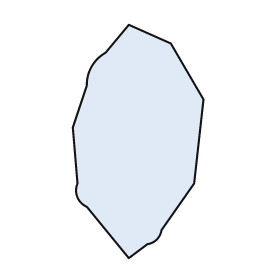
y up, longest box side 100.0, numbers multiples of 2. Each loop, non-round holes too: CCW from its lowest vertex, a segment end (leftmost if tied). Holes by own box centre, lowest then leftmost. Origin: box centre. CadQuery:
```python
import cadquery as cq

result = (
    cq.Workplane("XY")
    .moveTo(-4.0, -50.0)
    .lineTo(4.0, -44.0)
    .threePointArc((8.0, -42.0), (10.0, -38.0))
    .lineTo(24.0, -18.0)
    .lineTo(28.0, 18.0)
    .lineTo(14.0, 42.0)
    .lineTo(-4.0, 50.0)
    .lineTo(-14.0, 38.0)
    .threePointArc((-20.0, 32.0), (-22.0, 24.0))
    .lineTo(-28.0, 6.0)
    .lineTo(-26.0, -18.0)
    .threePointArc((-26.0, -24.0), (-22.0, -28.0))
    .close()
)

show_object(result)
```